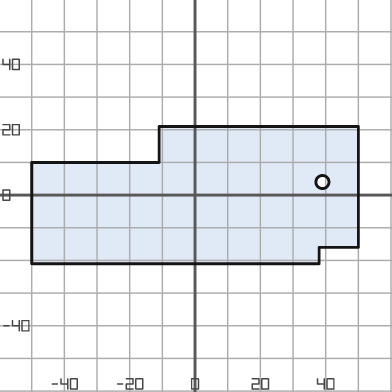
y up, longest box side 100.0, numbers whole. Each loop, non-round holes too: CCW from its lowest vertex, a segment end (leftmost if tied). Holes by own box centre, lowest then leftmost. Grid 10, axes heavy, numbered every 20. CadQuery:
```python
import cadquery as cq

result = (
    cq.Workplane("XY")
    .moveTo(-50.0, -21.0)
    .lineTo(38.0, -21.0)
    .lineTo(38.0, -16.0)
    .lineTo(50.0, -16.0)
    .lineTo(50.0, 21.0)
    .lineTo(-11.0, 21.0)
    .lineTo(-11.0, 10.0)
    .lineTo(-50.0, 10.0)
    .close()
    .moveTo(39.0, 4.0)
    .circle(2.0)
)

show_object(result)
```